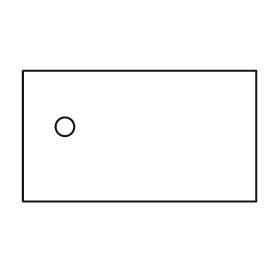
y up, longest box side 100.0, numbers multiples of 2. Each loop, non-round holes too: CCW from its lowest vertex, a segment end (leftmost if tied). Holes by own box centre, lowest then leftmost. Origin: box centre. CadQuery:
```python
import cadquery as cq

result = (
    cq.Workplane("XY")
    .moveTo(-50.0, -28.0)
    .lineTo(50.0, -28.0)
    .lineTo(50.0, 28.0)
    .lineTo(-50.0, 28.0)
    .close()
    .moveTo(-32.0, 4.0)
    .circle(4.0)
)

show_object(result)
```